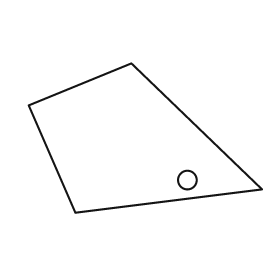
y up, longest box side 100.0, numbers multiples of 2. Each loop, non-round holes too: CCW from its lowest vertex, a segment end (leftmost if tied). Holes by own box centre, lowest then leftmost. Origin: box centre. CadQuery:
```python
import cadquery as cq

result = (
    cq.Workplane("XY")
    .moveTo(-30.0, -32.0)
    .lineTo(50.0, -22.0)
    .lineTo(-6.0, 32.0)
    .lineTo(-50.0, 14.0)
    .close()
    .moveTo(18.0, -18.0)
    .circle(4.0)
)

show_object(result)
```